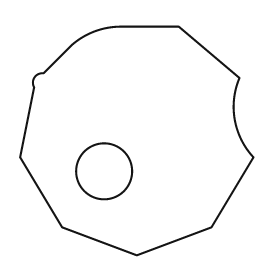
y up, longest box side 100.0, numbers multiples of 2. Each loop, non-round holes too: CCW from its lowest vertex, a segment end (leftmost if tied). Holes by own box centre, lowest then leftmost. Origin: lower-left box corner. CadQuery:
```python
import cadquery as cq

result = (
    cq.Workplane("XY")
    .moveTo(50.0, 0.0)
    .lineTo(82.0, 12.0)
    .lineTo(100.0, 42.0)
    .threePointArc((92.0, 58.0), (94.0, 76.0))
    .lineTo(68.0, 98.0)
    .lineTo(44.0, 98.0)
    .threePointArc((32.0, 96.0), (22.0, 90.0))
    .lineTo(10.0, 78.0)
    .threePointArc((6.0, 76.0), (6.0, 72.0))
    .lineTo(0.0, 42.0)
    .lineTo(18.0, 12.0)
    .close()
    .moveTo(36.0, 36.0)
    .circle(12.0)
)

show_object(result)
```